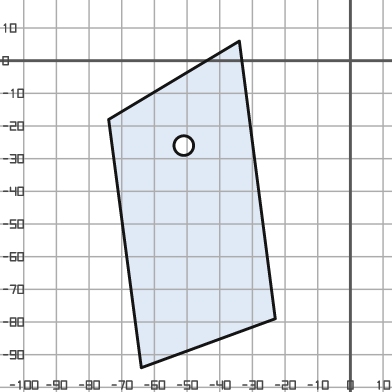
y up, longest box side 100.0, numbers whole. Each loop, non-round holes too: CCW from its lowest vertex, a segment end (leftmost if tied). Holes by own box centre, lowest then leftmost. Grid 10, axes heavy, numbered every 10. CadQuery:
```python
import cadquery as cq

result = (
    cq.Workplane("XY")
    .moveTo(-64.0, -94.0)
    .lineTo(-23.0, -79.0)
    .lineTo(-34.0, 6.0)
    .lineTo(-74.0, -18.0)
    .close()
    .moveTo(-51.0, -26.0)
    .circle(3.0)
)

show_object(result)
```